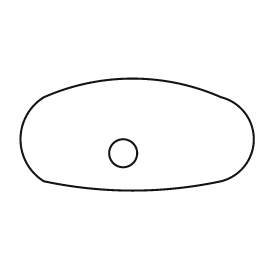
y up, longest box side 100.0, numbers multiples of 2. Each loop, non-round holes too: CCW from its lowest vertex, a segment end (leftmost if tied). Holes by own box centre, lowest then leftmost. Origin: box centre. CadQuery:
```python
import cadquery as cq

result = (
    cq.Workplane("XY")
    .moveTo(-40.0, -20.0)
    .threePointArc((-2.0, -24.0), (36.0, -20.0))
    .threePointArc((50.0, -2.0), (36.0, 16.0))
    .threePointArc((-2.0, 24.0), (-40.0, 16.0))
    .threePointArc((-50.0, -2.0), (-40.0, -20.0))
    .close()
    .moveTo(-6.0, -8.0)
    .circle(6.0)
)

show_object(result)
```